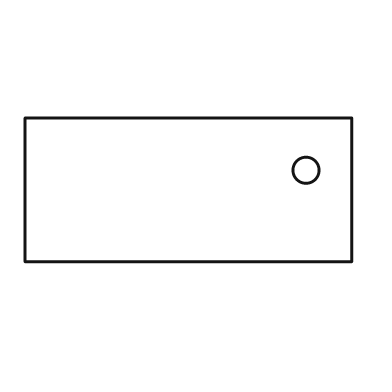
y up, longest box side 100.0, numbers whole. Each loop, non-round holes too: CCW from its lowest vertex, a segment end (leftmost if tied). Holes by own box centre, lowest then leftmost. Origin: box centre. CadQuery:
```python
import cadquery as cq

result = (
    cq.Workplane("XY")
    .moveTo(-50.0, -22.0)
    .lineTo(50.0, -22.0)
    .lineTo(50.0, 22.0)
    .lineTo(-50.0, 22.0)
    .close()
    .moveTo(36.0, 6.0)
    .circle(4.0)
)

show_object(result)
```